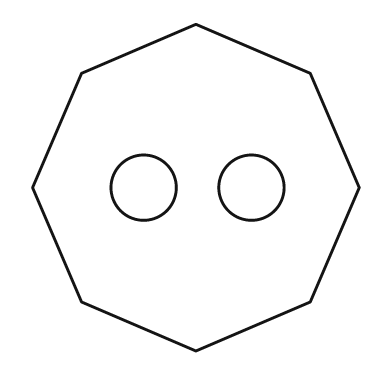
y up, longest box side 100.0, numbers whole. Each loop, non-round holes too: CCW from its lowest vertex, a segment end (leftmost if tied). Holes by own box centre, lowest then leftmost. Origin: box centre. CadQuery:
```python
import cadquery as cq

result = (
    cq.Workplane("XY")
    .moveTo(0.0, -50.0)
    .lineTo(35.0, -35.0)
    .lineTo(50.0, 0.0)
    .lineTo(35.0, 35.0)
    .lineTo(0.0, 50.0)
    .lineTo(-35.0, 35.0)
    .lineTo(-50.0, 0.0)
    .lineTo(-35.0, -35.0)
    .close()
    .moveTo(-16.0, 0.0)
    .circle(10.0)
    .moveTo(17.0, 0.0)
    .circle(10.0)
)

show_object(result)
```